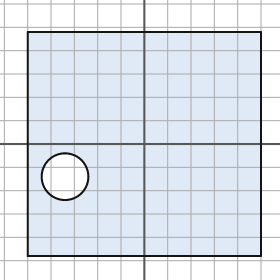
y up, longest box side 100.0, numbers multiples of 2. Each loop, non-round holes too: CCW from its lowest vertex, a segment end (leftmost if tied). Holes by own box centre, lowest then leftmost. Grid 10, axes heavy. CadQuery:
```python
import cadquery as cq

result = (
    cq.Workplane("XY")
    .moveTo(-50.0, -48.0)
    .lineTo(50.0, -48.0)
    .lineTo(50.0, 48.0)
    .lineTo(-50.0, 48.0)
    .close()
    .moveTo(-34.0, -14.0)
    .circle(10.0)
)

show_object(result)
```